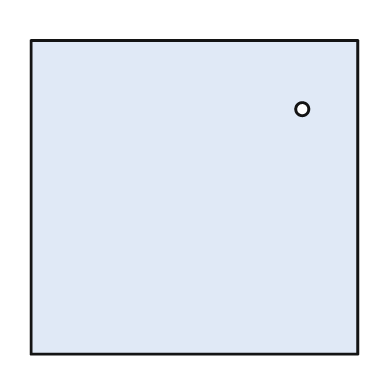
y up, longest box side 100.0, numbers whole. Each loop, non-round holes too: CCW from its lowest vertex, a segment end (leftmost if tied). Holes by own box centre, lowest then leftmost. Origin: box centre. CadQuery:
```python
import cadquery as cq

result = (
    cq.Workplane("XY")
    .moveTo(-50.0, -48.0)
    .lineTo(50.0, -48.0)
    .lineTo(50.0, 48.0)
    .lineTo(-50.0, 48.0)
    .close()
    .moveTo(33.0, 27.0)
    .circle(2.0)
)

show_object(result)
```